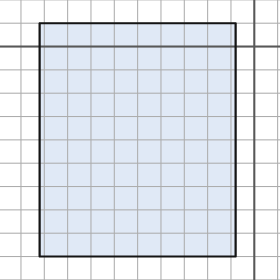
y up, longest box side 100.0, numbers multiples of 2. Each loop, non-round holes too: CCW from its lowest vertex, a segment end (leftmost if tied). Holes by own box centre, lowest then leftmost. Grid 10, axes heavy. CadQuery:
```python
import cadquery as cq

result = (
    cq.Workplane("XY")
    .moveTo(-92.0, -90.0)
    .lineTo(-8.0, -90.0)
    .lineTo(-8.0, 10.0)
    .lineTo(-92.0, 10.0)
    .close()
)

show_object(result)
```